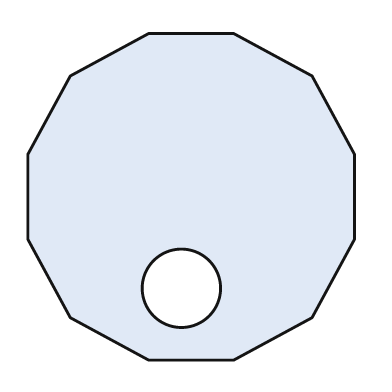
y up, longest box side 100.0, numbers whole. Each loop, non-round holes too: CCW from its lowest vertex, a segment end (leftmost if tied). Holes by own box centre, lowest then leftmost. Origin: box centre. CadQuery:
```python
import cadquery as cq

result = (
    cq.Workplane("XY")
    .moveTo(-13.0, -50.0)
    .lineTo(13.0, -50.0)
    .lineTo(37.0, -37.0)
    .lineTo(50.0, -13.0)
    .lineTo(50.0, 13.0)
    .lineTo(37.0, 37.0)
    .lineTo(13.0, 50.0)
    .lineTo(-13.0, 50.0)
    .lineTo(-37.0, 37.0)
    .lineTo(-50.0, 13.0)
    .lineTo(-50.0, -13.0)
    .lineTo(-37.0, -37.0)
    .close()
    .moveTo(-3.0, -28.0)
    .circle(12.0)
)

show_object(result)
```